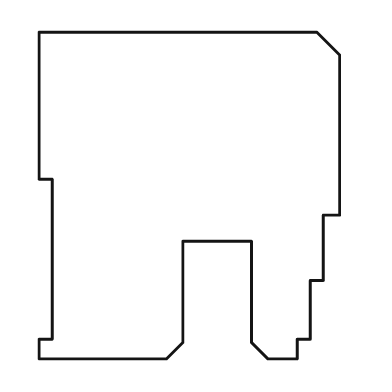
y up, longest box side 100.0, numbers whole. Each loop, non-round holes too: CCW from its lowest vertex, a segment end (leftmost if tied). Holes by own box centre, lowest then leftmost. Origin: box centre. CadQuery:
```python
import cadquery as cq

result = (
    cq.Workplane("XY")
    .moveTo(-46.0, -50.0)
    .lineTo(-7.0, -50.0)
    .lineTo(-2.0, -45.0)
    .lineTo(-2.0, -14.0)
    .lineTo(19.0, -14.0)
    .lineTo(19.0, -45.0)
    .lineTo(24.0, -50.0)
    .lineTo(33.0, -50.0)
    .lineTo(33.0, -44.0)
    .lineTo(37.0, -44.0)
    .lineTo(37.0, -26.0)
    .lineTo(41.0, -26.0)
    .lineTo(41.0, -6.0)
    .lineTo(46.0, -6.0)
    .lineTo(46.0, 43.0)
    .lineTo(39.0, 50.0)
    .lineTo(-46.0, 50.0)
    .lineTo(-46.0, 5.0)
    .lineTo(-42.0, 5.0)
    .lineTo(-42.0, -44.0)
    .lineTo(-46.0, -44.0)
    .close()
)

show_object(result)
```